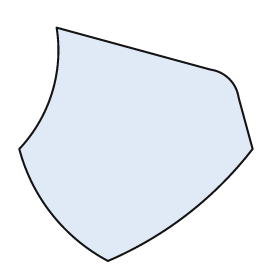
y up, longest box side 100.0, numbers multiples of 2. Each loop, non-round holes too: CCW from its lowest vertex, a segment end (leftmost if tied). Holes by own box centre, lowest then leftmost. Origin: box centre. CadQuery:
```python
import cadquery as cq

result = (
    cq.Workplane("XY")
    .moveTo(-12.0, -50.0)
    .threePointArc((22.0, -30.0), (50.0, -2.0))
    .lineTo(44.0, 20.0)
    .threePointArc((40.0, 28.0), (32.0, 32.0))
    .lineTo(-34.0, 50.0)
    .threePointArc((-36.0, 22.0), (-50.0, -2.0))
    .threePointArc((-36.0, -30.0), (-12.0, -50.0))
    .close()
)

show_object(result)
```